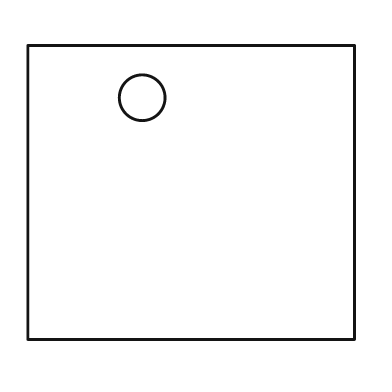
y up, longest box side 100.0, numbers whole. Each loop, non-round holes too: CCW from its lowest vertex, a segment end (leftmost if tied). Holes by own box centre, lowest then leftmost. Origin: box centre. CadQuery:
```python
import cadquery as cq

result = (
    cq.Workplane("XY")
    .moveTo(-50.0, -45.0)
    .lineTo(50.0, -45.0)
    .lineTo(50.0, 45.0)
    .lineTo(-50.0, 45.0)
    .close()
    .moveTo(-15.0, 29.0)
    .circle(7.0)
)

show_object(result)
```